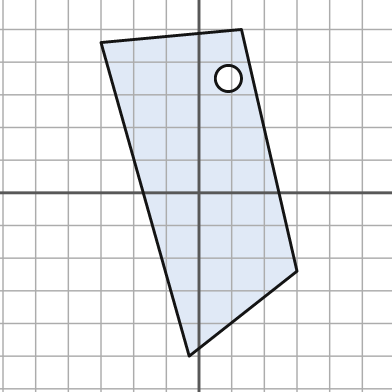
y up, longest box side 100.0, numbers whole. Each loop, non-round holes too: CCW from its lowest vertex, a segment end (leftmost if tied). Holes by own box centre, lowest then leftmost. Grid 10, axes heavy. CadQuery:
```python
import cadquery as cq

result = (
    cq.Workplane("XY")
    .moveTo(-3.0, -50.0)
    .lineTo(30.0, -24.0)
    .lineTo(13.0, 50.0)
    .lineTo(-30.0, 46.0)
    .close()
    .moveTo(9.0, 35.0)
    .circle(4.0)
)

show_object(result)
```